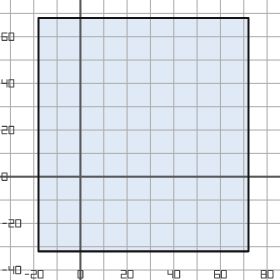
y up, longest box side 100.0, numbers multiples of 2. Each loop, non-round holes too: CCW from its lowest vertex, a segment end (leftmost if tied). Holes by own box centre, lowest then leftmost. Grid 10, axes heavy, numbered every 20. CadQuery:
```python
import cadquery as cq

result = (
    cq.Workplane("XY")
    .moveTo(-18.0, -32.0)
    .lineTo(72.0, -32.0)
    .lineTo(72.0, 68.0)
    .lineTo(-18.0, 68.0)
    .close()
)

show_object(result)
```